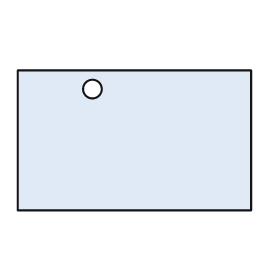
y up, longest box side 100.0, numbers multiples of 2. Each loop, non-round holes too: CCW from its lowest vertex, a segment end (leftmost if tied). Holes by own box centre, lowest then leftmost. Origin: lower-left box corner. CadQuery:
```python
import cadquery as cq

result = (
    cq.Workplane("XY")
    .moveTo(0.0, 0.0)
    .lineTo(100.0, 0.0)
    .lineTo(100.0, 60.0)
    .lineTo(0.0, 60.0)
    .close()
    .moveTo(32.0, 52.0)
    .circle(4.0)
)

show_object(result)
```